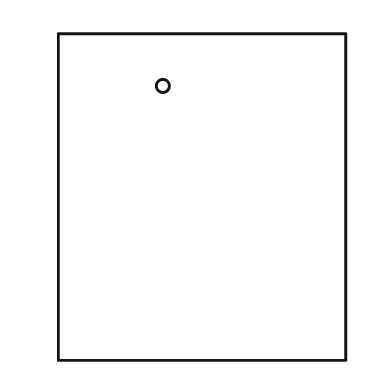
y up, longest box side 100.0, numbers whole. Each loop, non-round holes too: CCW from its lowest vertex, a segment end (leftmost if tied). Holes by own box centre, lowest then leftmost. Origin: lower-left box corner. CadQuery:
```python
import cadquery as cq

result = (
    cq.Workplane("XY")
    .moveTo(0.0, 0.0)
    .lineTo(88.0, 0.0)
    .lineTo(88.0, 100.0)
    .lineTo(0.0, 100.0)
    .close()
    .moveTo(32.0, 84.0)
    .circle(2.0)
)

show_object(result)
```